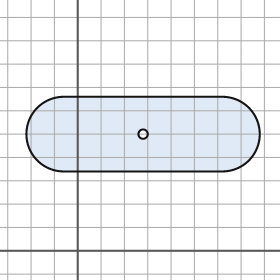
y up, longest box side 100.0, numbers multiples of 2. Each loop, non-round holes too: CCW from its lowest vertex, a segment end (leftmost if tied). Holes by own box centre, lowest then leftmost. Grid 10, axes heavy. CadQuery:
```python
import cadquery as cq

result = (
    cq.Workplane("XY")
    .moveTo(-6.0, 34.0)
    .lineTo(62.0, 34.0)
    .threePointArc((78.0, 50.0), (62.0, 66.0))
    .lineTo(-6.0, 66.0)
    .threePointArc((-22.0, 50.0), (-6.0, 34.0))
    .close()
    .moveTo(28.0, 50.0)
    .circle(2.0)
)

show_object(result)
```